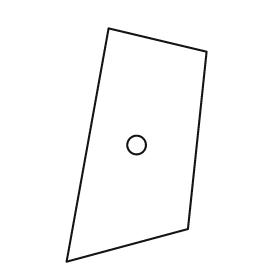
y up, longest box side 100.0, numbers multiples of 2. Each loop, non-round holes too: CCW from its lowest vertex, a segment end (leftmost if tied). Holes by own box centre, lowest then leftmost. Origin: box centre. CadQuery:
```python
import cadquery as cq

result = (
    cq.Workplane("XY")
    .moveTo(-30.0, -50.0)
    .lineTo(22.0, -36.0)
    .lineTo(30.0, 40.0)
    .lineTo(-12.0, 50.0)
    .close()
    .moveTo(0.0, 0.0)
    .circle(4.0)
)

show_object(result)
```